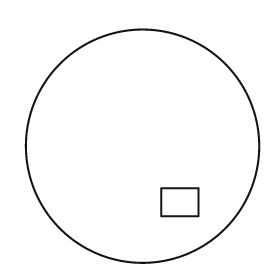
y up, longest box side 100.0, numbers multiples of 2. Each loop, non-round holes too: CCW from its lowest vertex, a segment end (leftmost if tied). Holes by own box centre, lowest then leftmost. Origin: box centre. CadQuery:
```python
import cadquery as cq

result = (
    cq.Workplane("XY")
    .moveTo(0.0, 0.0)
    .circle(50.0)
    .moveTo(8.0, -30.0)
    .lineTo(24.0, -30.0)
    .lineTo(24.0, -18.0)
    .lineTo(8.0, -18.0)
    .close()
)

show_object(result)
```